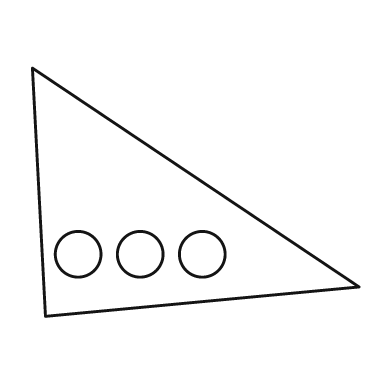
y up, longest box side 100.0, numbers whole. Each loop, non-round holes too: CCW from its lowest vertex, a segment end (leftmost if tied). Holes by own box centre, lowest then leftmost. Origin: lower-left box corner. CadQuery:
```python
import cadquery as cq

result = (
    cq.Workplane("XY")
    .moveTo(4.0, 0.0)
    .lineTo(100.0, 9.0)
    .lineTo(0.0, 76.0)
    .close()
    .moveTo(14.0, 19.0)
    .circle(7.0)
    .moveTo(33.0, 19.0)
    .circle(7.0)
    .moveTo(52.0, 19.0)
    .circle(7.0)
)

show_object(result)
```